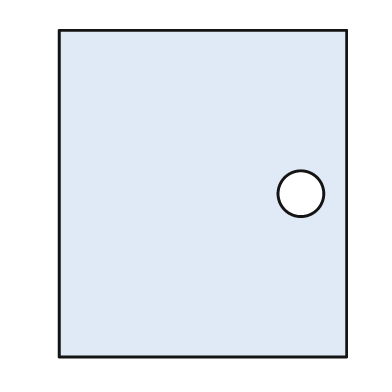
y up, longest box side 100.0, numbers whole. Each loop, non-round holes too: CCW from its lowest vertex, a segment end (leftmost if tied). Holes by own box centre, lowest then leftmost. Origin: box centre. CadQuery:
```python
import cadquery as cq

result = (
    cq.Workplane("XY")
    .moveTo(-44.0, -50.0)
    .lineTo(44.0, -50.0)
    .lineTo(44.0, 50.0)
    .lineTo(-44.0, 50.0)
    .close()
    .moveTo(30.0, 0.0)
    .circle(7.0)
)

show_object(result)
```